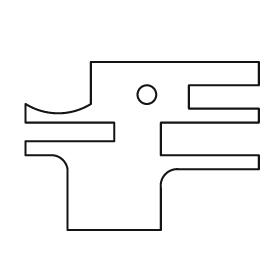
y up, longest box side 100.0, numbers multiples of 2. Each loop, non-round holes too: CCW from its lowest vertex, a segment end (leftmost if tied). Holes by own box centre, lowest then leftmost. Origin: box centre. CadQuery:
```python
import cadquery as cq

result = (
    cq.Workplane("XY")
    .moveTo(-32.0, -36.0)
    .lineTo(8.0, -36.0)
    .lineTo(8.0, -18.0)
    .threePointArc((10.0, -12.0), (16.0, -10.0))
    .lineTo(50.0, -10.0)
    .lineTo(50.0, -4.0)
    .lineTo(8.0, -4.0)
    .lineTo(8.0, 10.0)
    .lineTo(50.0, 10.0)
    .lineTo(50.0, 16.0)
    .lineTo(20.0, 16.0)
    .lineTo(20.0, 26.0)
    .lineTo(50.0, 26.0)
    .lineTo(50.0, 36.0)
    .lineTo(-22.0, 36.0)
    .lineTo(-22.0, 18.0)
    .threePointArc((-36.0, 14.0), (-50.0, 18.0))
    .lineTo(-50.0, 10.0)
    .lineTo(-12.0, 10.0)
    .lineTo(-12.0, 2.0)
    .lineTo(-50.0, 2.0)
    .lineTo(-50.0, -4.0)
    .lineTo(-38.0, -4.0)
    .threePointArc((-34.0, -6.0), (-32.0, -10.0))
    .close()
    .moveTo(2.0, 22.0)
    .circle(4.0)
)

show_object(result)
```